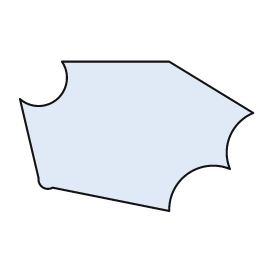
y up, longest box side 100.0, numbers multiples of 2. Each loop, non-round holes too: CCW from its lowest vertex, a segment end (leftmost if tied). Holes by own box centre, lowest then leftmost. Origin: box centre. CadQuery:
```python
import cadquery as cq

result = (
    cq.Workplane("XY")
    .moveTo(14.0, -32.0)
    .threePointArc((22.0, -16.0), (40.0, -14.0))
    .threePointArc((40.0, 0.0), (50.0, 10.0))
    .lineTo(14.0, 32.0)
    .lineTo(-32.0, 32.0)
    .threePointArc((-34.0, 16.0), (-50.0, 16.0))
    .lineTo(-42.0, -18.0)
    .threePointArc((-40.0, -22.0), (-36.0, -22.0))
    .close()
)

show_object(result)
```